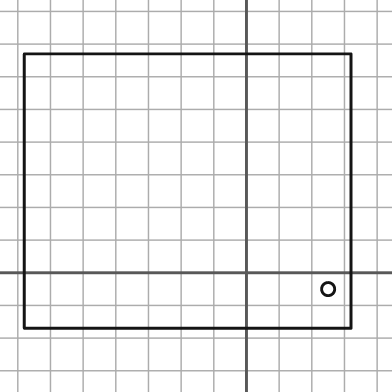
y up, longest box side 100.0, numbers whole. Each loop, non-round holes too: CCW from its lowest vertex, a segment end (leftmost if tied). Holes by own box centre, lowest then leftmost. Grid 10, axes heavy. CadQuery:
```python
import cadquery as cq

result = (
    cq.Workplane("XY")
    .moveTo(-68.0, -17.0)
    .lineTo(32.0, -17.0)
    .lineTo(32.0, 67.0)
    .lineTo(-68.0, 67.0)
    .close()
    .moveTo(25.0, -5.0)
    .circle(2.0)
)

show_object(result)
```